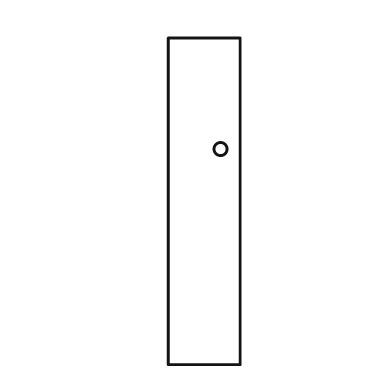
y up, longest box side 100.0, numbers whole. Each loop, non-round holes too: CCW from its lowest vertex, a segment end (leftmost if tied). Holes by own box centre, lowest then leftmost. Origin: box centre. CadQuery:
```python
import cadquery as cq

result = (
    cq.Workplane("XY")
    .moveTo(-11.0, -50.0)
    .lineTo(11.0, -50.0)
    .lineTo(11.0, 50.0)
    .lineTo(-11.0, 50.0)
    .close()
    .moveTo(5.0, 16.0)
    .circle(2.0)
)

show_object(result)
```